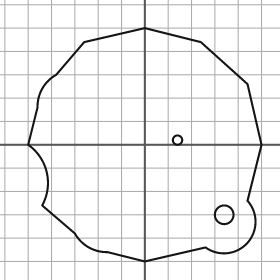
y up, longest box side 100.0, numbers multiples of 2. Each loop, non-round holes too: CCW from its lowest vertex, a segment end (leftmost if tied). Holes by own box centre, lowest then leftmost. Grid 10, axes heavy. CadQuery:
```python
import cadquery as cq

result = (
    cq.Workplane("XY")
    .moveTo(0.0, -50.0)
    .lineTo(26.0, -44.0)
    .threePointArc((44.0, -42.0), (44.0, -24.0))
    .lineTo(50.0, 0.0)
    .lineTo(44.0, 26.0)
    .lineTo(24.0, 44.0)
    .lineTo(0.0, 50.0)
    .lineTo(-26.0, 44.0)
    .lineTo(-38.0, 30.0)
    .threePointArc((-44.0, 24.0), (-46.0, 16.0))
    .lineTo(-50.0, 0.0)
    .threePointArc((-42.0, -12.0), (-44.0, -26.0))
    .lineTo(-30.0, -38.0)
    .threePointArc((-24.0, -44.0), (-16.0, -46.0))
    .close()
    .moveTo(34.0, -30.0)
    .circle(4.0)
    .moveTo(14.0, 2.0)
    .circle(2.0)
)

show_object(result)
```